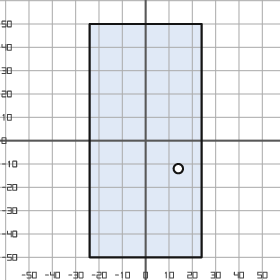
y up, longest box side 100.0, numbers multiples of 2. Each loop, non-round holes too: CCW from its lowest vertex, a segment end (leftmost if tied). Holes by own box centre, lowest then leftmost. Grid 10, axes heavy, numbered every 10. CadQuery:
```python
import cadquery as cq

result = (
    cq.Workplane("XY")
    .moveTo(-24.0, -50.0)
    .lineTo(24.0, -50.0)
    .lineTo(24.0, 50.0)
    .lineTo(-24.0, 50.0)
    .close()
    .moveTo(14.0, -12.0)
    .circle(2.0)
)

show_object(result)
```